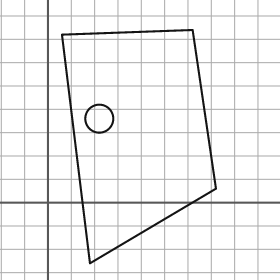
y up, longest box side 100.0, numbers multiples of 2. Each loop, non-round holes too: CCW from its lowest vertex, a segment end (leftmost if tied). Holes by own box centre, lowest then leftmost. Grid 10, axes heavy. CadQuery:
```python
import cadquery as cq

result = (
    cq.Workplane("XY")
    .moveTo(18.0, -26.0)
    .lineTo(72.0, 6.0)
    .lineTo(62.0, 74.0)
    .lineTo(6.0, 72.0)
    .close()
    .moveTo(22.0, 36.0)
    .circle(6.0)
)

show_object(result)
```